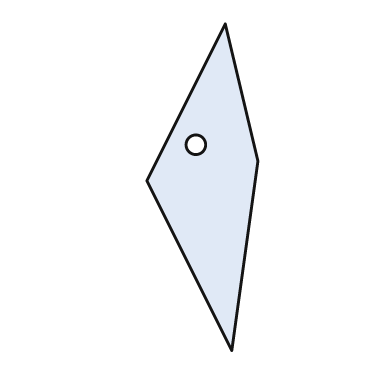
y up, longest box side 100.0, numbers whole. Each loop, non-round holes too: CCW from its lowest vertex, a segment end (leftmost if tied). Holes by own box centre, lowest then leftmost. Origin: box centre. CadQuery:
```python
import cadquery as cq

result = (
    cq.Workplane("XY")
    .moveTo(9.0, -50.0)
    .lineTo(17.0, 8.0)
    .lineTo(7.0, 50.0)
    .lineTo(-17.0, 2.0)
    .close()
    .moveTo(-2.0, 13.0)
    .circle(3.0)
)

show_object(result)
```